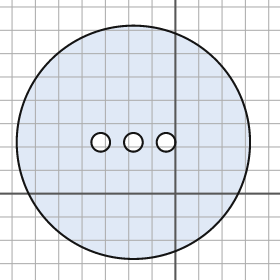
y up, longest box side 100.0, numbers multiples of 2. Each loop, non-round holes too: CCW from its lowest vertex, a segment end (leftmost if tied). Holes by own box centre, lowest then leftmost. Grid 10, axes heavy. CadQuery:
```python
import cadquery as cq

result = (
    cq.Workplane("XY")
    .moveTo(-18.0, 22.0)
    .circle(50.0)
    .moveTo(-32.0, 22.0)
    .circle(4.0)
    .moveTo(-18.0, 22.0)
    .circle(4.0)
    .moveTo(-4.0, 22.0)
    .circle(4.0)
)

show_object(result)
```